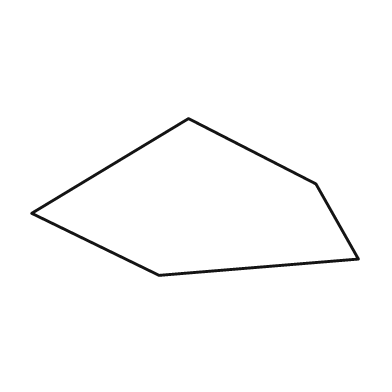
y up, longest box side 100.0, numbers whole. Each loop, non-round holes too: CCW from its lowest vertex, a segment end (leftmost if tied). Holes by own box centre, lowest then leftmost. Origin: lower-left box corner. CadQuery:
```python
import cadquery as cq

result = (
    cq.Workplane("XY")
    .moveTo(39.0, 0.0)
    .lineTo(100.0, 5.0)
    .lineTo(87.0, 28.0)
    .lineTo(48.0, 48.0)
    .lineTo(0.0, 19.0)
    .close()
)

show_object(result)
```